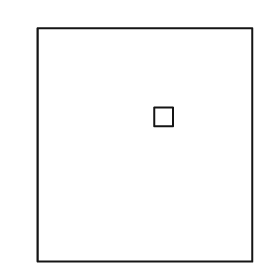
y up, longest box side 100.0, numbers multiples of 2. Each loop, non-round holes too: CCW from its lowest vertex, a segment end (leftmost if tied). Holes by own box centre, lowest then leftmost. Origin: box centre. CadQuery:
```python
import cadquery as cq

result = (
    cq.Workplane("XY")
    .moveTo(-46.0, -50.0)
    .lineTo(46.0, -50.0)
    .lineTo(46.0, 50.0)
    .lineTo(-46.0, 50.0)
    .close()
    .moveTo(4.0, 8.0)
    .lineTo(12.0, 8.0)
    .lineTo(12.0, 16.0)
    .lineTo(4.0, 16.0)
    .close()
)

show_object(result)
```